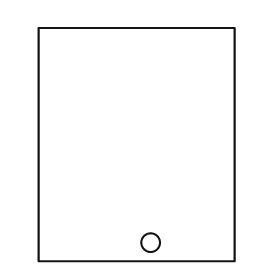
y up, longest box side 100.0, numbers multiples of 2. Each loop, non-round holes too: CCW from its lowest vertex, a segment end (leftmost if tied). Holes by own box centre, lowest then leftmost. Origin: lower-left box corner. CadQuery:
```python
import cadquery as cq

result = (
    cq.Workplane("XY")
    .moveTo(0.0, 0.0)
    .lineTo(84.0, 0.0)
    .lineTo(84.0, 100.0)
    .lineTo(0.0, 100.0)
    .close()
    .moveTo(48.0, 8.0)
    .circle(4.0)
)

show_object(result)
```